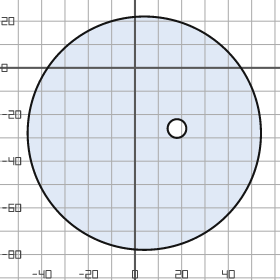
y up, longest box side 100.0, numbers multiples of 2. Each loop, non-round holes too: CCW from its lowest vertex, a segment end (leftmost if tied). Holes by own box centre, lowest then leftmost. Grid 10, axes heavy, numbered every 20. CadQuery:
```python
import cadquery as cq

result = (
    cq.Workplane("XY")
    .moveTo(4.0, -28.0)
    .circle(50.0)
    .moveTo(18.0, -26.0)
    .circle(4.0)
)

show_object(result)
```